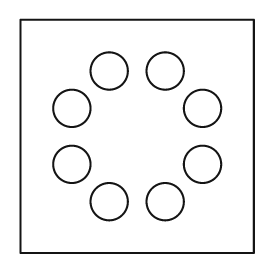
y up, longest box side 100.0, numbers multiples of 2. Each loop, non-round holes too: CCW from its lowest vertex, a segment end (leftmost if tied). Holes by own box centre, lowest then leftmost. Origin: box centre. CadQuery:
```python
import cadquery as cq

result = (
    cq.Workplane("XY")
    .moveTo(-50.0, -50.0)
    .lineTo(50.0, -50.0)
    .lineTo(50.0, 50.0)
    .lineTo(-50.0, 50.0)
    .close()
    .moveTo(-12.0, -28.0)
    .circle(8.0)
    .moveTo(12.0, -28.0)
    .circle(8.0)
    .moveTo(-28.0, -12.0)
    .circle(8.0)
    .moveTo(28.0, -12.0)
    .circle(8.0)
    .moveTo(-28.0, 12.0)
    .circle(8.0)
    .moveTo(28.0, 12.0)
    .circle(8.0)
    .moveTo(-12.0, 28.0)
    .circle(8.0)
    .moveTo(12.0, 28.0)
    .circle(8.0)
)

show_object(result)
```